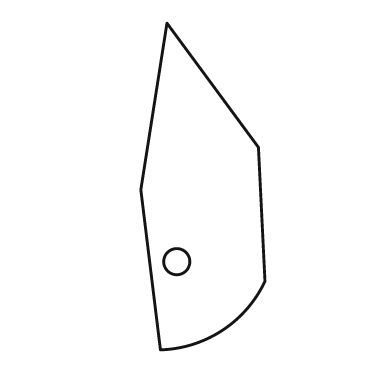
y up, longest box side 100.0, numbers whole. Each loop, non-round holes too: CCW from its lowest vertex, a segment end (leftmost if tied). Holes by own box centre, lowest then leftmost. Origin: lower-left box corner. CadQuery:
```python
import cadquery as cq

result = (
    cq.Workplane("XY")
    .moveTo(6.0, 0.0)
    .threePointArc((25.0, 6.0), (38.0, 21.0))
    .lineTo(36.0, 62.0)
    .lineTo(8.0, 100.0)
    .lineTo(0.0, 49.0)
    .close()
    .moveTo(11.0, 27.0)
    .circle(4.0)
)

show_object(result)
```